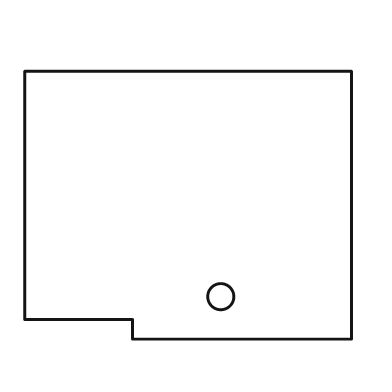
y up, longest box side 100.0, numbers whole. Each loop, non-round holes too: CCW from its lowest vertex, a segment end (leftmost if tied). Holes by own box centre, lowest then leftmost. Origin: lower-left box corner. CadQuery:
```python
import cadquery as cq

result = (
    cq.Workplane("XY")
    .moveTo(33.0, 0.0)
    .lineTo(100.0, 0.0)
    .lineTo(100.0, 82.0)
    .lineTo(0.0, 82.0)
    .lineTo(0.0, 6.0)
    .lineTo(33.0, 6.0)
    .close()
    .moveTo(60.0, 13.0)
    .circle(4.0)
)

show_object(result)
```